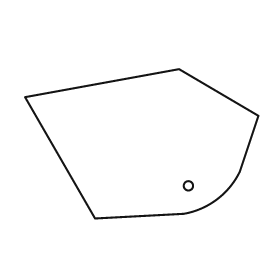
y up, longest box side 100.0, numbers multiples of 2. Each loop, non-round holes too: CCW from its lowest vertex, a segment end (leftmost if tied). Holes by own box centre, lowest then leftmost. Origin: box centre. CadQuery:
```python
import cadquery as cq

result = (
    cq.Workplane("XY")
    .moveTo(-20.0, -32.0)
    .lineTo(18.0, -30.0)
    .threePointArc((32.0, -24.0), (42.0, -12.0))
    .lineTo(50.0, 12.0)
    .lineTo(16.0, 32.0)
    .lineTo(-50.0, 20.0)
    .close()
    .moveTo(20.0, -18.0)
    .circle(2.0)
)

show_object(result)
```